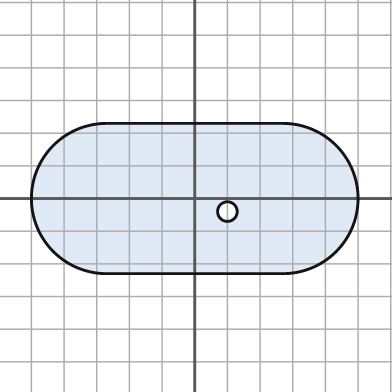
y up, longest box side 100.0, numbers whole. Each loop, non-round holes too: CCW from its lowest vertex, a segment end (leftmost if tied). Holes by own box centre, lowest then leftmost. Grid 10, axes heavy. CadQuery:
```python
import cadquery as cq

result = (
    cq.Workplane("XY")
    .moveTo(-27.0, -23.0)
    .lineTo(27.0, -23.0)
    .threePointArc((50.0, 0.0), (27.0, 23.0))
    .lineTo(-27.0, 23.0)
    .threePointArc((-50.0, 0.0), (-27.0, -23.0))
    .close()
    .moveTo(10.0, -4.0)
    .circle(3.0)
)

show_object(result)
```